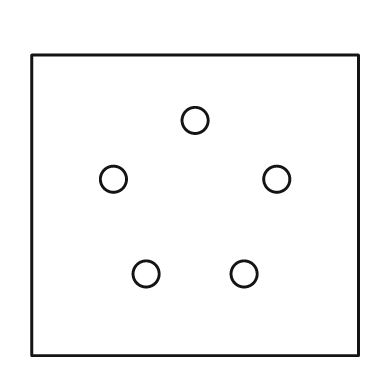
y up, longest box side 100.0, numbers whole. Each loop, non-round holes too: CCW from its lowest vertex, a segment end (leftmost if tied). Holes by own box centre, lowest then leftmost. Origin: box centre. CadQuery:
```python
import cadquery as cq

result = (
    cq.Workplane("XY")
    .moveTo(-50.0, -46.0)
    .lineTo(50.0, -46.0)
    .lineTo(50.0, 46.0)
    .lineTo(-50.0, 46.0)
    .close()
    .moveTo(-15.0, -21.0)
    .circle(4.0)
    .moveTo(15.0, -21.0)
    .circle(4.0)
    .moveTo(-25.0, 8.0)
    .circle(4.0)
    .moveTo(25.0, 8.0)
    .circle(4.0)
    .moveTo(0.0, 26.0)
    .circle(4.0)
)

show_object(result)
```